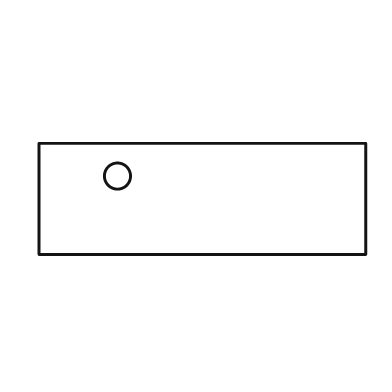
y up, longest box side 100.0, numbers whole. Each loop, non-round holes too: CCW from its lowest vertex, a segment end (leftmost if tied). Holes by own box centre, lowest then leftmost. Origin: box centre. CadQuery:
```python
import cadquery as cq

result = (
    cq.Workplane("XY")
    .moveTo(-50.0, -17.0)
    .lineTo(50.0, -17.0)
    .lineTo(50.0, 17.0)
    .lineTo(-50.0, 17.0)
    .close()
    .moveTo(-26.0, 7.0)
    .circle(4.0)
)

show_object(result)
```